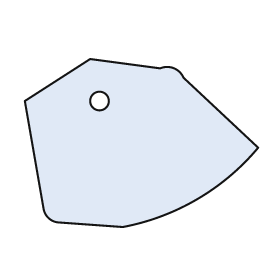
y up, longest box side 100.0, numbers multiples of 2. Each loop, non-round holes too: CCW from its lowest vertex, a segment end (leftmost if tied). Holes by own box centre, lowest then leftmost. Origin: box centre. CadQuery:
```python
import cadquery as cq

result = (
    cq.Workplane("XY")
    .moveTo(-8.0, -36.0)
    .threePointArc((24.0, -24.0), (50.0, -2.0))
    .lineTo(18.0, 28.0)
    .threePointArc((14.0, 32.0), (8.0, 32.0))
    .lineTo(-22.0, 36.0)
    .lineTo(-50.0, 18.0)
    .lineTo(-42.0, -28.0)
    .threePointArc((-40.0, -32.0), (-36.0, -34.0))
    .close()
    .moveTo(-18.0, 18.0)
    .circle(4.0)
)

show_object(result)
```